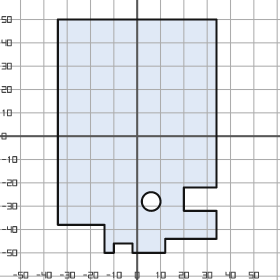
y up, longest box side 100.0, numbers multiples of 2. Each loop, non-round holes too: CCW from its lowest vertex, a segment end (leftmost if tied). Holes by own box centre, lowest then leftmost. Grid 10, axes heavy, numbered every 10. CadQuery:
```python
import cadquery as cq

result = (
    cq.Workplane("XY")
    .moveTo(-14.0, -50.0)
    .lineTo(-10.0, -50.0)
    .lineTo(-10.0, -46.0)
    .lineTo(-2.0, -46.0)
    .lineTo(-2.0, -50.0)
    .lineTo(12.0, -50.0)
    .lineTo(12.0, -44.0)
    .lineTo(34.0, -44.0)
    .lineTo(34.0, -32.0)
    .lineTo(20.0, -32.0)
    .lineTo(20.0, -22.0)
    .lineTo(34.0, -22.0)
    .lineTo(34.0, 50.0)
    .lineTo(-34.0, 50.0)
    .lineTo(-34.0, -38.0)
    .lineTo(-14.0, -38.0)
    .close()
    .moveTo(6.0, -28.0)
    .circle(4.0)
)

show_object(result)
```